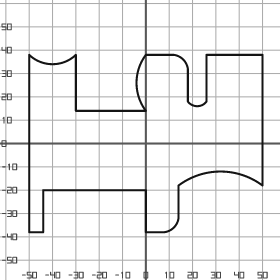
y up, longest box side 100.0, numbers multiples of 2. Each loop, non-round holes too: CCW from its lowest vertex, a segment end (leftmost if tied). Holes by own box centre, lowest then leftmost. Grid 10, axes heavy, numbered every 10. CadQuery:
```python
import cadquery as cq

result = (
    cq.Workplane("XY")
    .moveTo(-50.0, -38.0)
    .lineTo(-44.0, -38.0)
    .lineTo(-44.0, -20.0)
    .lineTo(0.0, -20.0)
    .lineTo(0.0, -38.0)
    .lineTo(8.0, -38.0)
    .threePointArc((12.0, -36.0), (14.0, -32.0))
    .lineTo(14.0, -18.0)
    .threePointArc((32.0, -12.0), (50.0, -18.0))
    .lineTo(50.0, 38.0)
    .lineTo(26.0, 38.0)
    .lineTo(26.0, 18.0)
    .threePointArc((22.0, 16.0), (18.0, 18.0))
    .lineTo(18.0, 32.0)
    .threePointArc((16.0, 36.0), (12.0, 38.0))
    .lineTo(0.0, 38.0)
    .threePointArc((-4.0, 26.0), (0.0, 14.0))
    .lineTo(-30.0, 14.0)
    .lineTo(-30.0, 38.0)
    .threePointArc((-40.0, 34.0), (-50.0, 38.0))
    .close()
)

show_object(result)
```